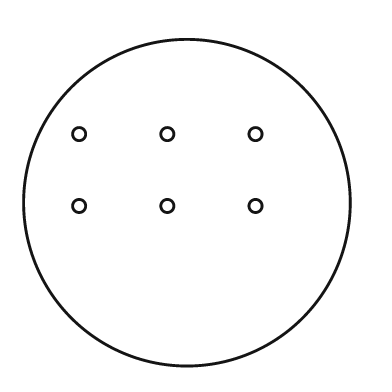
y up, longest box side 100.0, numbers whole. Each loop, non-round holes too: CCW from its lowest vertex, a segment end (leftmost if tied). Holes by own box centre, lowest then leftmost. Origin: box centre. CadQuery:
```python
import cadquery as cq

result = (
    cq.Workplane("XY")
    .moveTo(0.0, 0.0)
    .circle(50.0)
    .moveTo(-33.0, -1.0)
    .circle(2.0)
    .moveTo(-6.0, -1.0)
    .circle(2.0)
    .moveTo(21.0, -1.0)
    .circle(2.0)
    .moveTo(-33.0, 21.0)
    .circle(2.0)
    .moveTo(-6.0, 21.0)
    .circle(2.0)
    .moveTo(21.0, 21.0)
    .circle(2.0)
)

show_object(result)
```